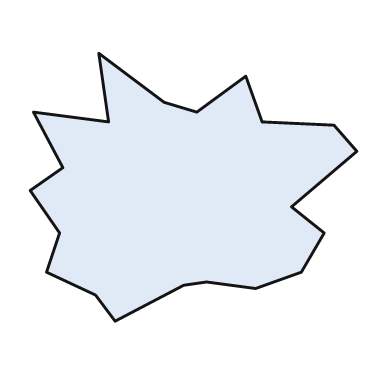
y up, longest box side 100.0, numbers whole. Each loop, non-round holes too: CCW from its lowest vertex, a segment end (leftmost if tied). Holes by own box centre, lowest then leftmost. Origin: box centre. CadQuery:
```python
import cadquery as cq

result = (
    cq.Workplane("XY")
    .moveTo(-24.0, -41.0)
    .lineTo(-3.0, -30.0)
    .lineTo(4.0, -29.0)
    .lineTo(19.0, -31.0)
    .lineTo(33.0, -26.0)
    .lineTo(40.0, -14.0)
    .lineTo(30.0, -6.0)
    .lineTo(50.0, 11.0)
    .lineTo(43.0, 19.0)
    .lineTo(21.0, 20.0)
    .lineTo(16.0, 34.0)
    .lineTo(1.0, 23.0)
    .lineTo(-9.0, 26.0)
    .lineTo(-29.0, 41.0)
    .lineTo(-26.0, 20.0)
    .lineTo(-49.0, 23.0)
    .lineTo(-40.0, 6.0)
    .lineTo(-50.0, -1.0)
    .lineTo(-41.0, -14.0)
    .lineTo(-45.0, -26.0)
    .lineTo(-30.0, -33.0)
    .close()
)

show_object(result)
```